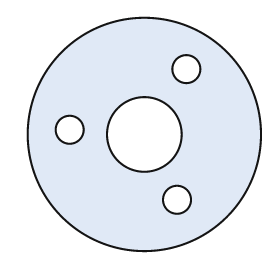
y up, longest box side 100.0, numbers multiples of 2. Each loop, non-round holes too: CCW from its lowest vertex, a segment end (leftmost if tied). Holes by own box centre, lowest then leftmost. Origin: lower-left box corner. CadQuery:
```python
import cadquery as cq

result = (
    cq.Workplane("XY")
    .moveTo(50.0, 50.0)
    .circle(50.0)
    .moveTo(64.0, 22.0)
    .circle(6.0)
    .moveTo(50.0, 50.0)
    .circle(16.0)
    .moveTo(18.0, 52.0)
    .circle(6.0)
    .moveTo(68.0, 78.0)
    .circle(6.0)
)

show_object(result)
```